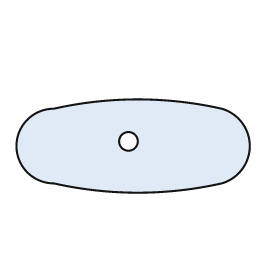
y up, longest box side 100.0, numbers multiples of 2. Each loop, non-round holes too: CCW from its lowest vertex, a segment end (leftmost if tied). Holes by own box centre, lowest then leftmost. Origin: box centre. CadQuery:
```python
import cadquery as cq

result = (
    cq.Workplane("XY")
    .moveTo(-34.0, -16.0)
    .threePointArc((2.0, -20.0), (38.0, -16.0))
    .threePointArc((50.0, 0.0), (38.0, 16.0))
    .threePointArc((2.0, 20.0), (-34.0, 16.0))
    .threePointArc((-50.0, 0.0), (-34.0, -16.0))
    .close()
    .moveTo(-2.0, 2.0)
    .circle(4.0)
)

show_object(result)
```